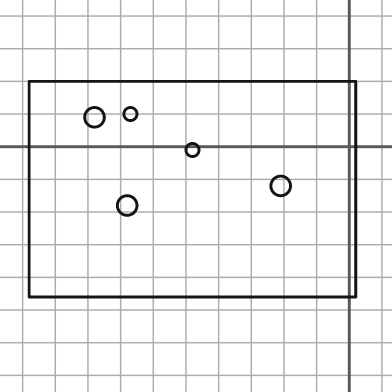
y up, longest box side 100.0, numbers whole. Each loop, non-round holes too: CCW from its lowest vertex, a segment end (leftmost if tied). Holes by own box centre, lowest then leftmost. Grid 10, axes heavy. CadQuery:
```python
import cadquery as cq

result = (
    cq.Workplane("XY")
    .moveTo(-98.0, -46.0)
    .lineTo(2.0, -46.0)
    .lineTo(2.0, 20.0)
    .lineTo(-98.0, 20.0)
    .close()
    .moveTo(-68.0, -18.0)
    .circle(3.0)
    .moveTo(-21.0, -12.0)
    .circle(3.0)
    .moveTo(-48.0, -1.0)
    .circle(2.0)
    .moveTo(-78.0, 9.0)
    .circle(3.0)
    .moveTo(-67.0, 10.0)
    .circle(2.0)
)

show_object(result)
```